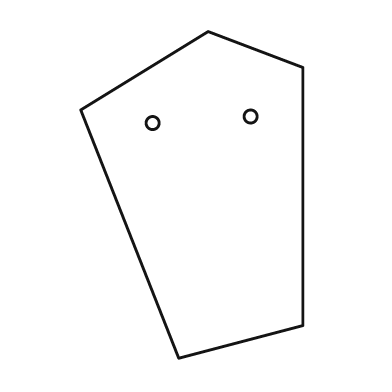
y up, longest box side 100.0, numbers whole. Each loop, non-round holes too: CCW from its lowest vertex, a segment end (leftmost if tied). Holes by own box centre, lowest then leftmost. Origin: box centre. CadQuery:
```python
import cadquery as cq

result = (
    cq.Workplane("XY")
    .moveTo(-4.0, -50.0)
    .lineTo(34.0, -40.0)
    .lineTo(34.0, 39.0)
    .lineTo(5.0, 50.0)
    .lineTo(-34.0, 26.0)
    .close()
    .moveTo(-12.0, 22.0)
    .circle(2.0)
    .moveTo(18.0, 24.0)
    .circle(2.0)
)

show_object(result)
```